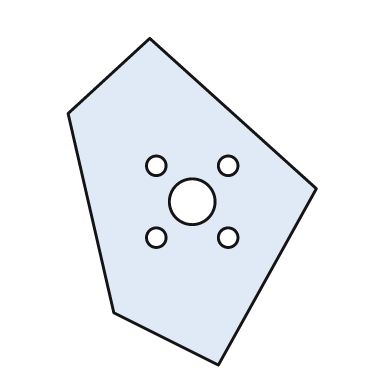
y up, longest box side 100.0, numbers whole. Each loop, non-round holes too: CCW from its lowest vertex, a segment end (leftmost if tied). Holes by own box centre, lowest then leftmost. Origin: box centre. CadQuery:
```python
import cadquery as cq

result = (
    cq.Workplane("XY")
    .moveTo(8.0, -50.0)
    .lineTo(38.0, 4.0)
    .lineTo(-13.0, 50.0)
    .lineTo(-38.0, 27.0)
    .lineTo(-24.0, -34.0)
    .close()
    .moveTo(-11.0, -11.0)
    .circle(3.0)
    .moveTo(11.0, -11.0)
    .circle(3.0)
    .moveTo(0.0, 0.0)
    .circle(7.0)
    .moveTo(-11.0, 11.0)
    .circle(3.0)
    .moveTo(11.0, 11.0)
    .circle(3.0)
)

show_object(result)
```